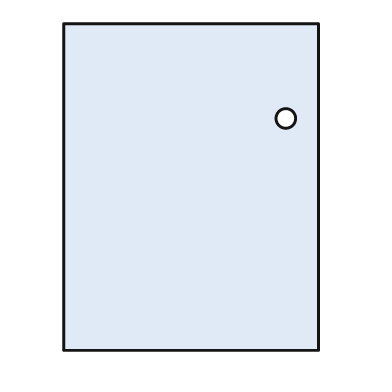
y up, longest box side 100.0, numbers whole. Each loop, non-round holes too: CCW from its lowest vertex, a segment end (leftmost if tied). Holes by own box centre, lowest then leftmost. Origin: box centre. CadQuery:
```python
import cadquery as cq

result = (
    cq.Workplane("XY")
    .moveTo(-39.0, -50.0)
    .lineTo(39.0, -50.0)
    .lineTo(39.0, 50.0)
    .lineTo(-39.0, 50.0)
    .close()
    .moveTo(29.0, 21.0)
    .circle(3.0)
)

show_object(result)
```